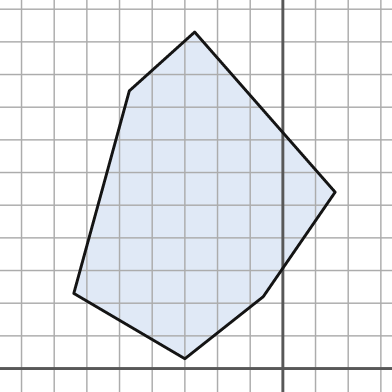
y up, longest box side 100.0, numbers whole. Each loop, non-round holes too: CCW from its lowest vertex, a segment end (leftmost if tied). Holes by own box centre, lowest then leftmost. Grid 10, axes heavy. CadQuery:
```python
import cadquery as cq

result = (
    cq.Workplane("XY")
    .moveTo(-30.0, 3.0)
    .lineTo(-6.0, 22.0)
    .lineTo(16.0, 54.0)
    .lineTo(-27.0, 103.0)
    .lineTo(-47.0, 85.0)
    .lineTo(-64.0, 23.0)
    .close()
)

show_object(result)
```